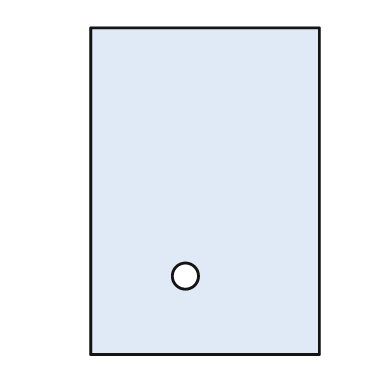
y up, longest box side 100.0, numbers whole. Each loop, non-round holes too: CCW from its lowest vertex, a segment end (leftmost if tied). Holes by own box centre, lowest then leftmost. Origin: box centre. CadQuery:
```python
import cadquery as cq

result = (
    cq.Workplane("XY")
    .moveTo(-35.0, -50.0)
    .lineTo(35.0, -50.0)
    .lineTo(35.0, 50.0)
    .lineTo(-35.0, 50.0)
    .close()
    .moveTo(-6.0, -26.0)
    .circle(4.0)
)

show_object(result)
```